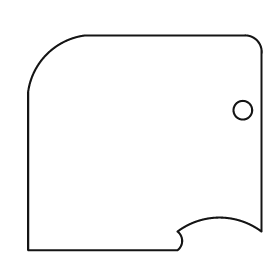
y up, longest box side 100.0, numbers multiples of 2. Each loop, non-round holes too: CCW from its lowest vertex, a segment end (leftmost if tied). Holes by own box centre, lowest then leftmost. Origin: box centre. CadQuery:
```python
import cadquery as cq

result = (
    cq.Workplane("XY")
    .moveTo(-50.0, -46.0)
    .lineTo(14.0, -46.0)
    .threePointArc((16.0, -42.0), (14.0, -38.0))
    .threePointArc((32.0, -32.0), (50.0, -38.0))
    .lineTo(50.0, 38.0)
    .threePointArc((48.0, 44.0), (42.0, 46.0))
    .lineTo(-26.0, 46.0)
    .threePointArc((-42.0, 38.0), (-50.0, 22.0))
    .close()
    .moveTo(42.0, 14.0)
    .circle(4.0)
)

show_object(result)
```